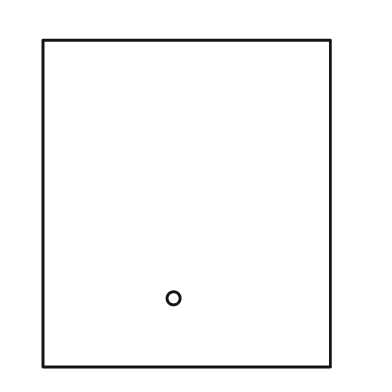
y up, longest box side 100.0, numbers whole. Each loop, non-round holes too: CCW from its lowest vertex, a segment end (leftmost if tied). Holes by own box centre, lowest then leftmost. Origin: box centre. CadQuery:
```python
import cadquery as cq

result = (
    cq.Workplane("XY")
    .moveTo(-44.0, -50.0)
    .lineTo(44.0, -50.0)
    .lineTo(44.0, 50.0)
    .lineTo(-44.0, 50.0)
    .close()
    .moveTo(-4.0, -29.0)
    .circle(2.0)
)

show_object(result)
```